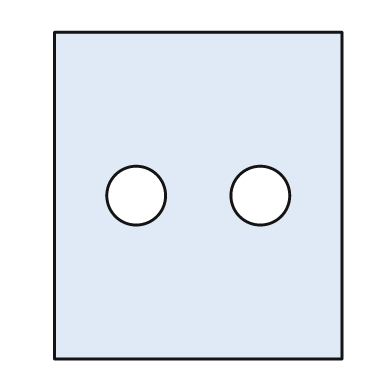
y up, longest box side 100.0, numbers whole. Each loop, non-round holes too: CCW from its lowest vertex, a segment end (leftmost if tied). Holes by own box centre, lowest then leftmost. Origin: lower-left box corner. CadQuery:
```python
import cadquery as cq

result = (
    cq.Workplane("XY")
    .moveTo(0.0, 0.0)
    .lineTo(88.0, 0.0)
    .lineTo(88.0, 100.0)
    .lineTo(0.0, 100.0)
    .close()
    .moveTo(25.0, 50.0)
    .circle(9.0)
    .moveTo(63.0, 50.0)
    .circle(9.0)
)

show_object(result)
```